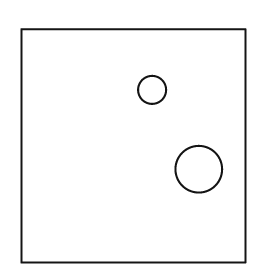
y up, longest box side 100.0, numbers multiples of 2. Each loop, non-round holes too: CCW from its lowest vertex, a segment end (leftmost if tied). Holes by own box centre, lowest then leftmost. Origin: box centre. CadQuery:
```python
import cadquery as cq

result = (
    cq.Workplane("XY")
    .moveTo(-48.0, -50.0)
    .lineTo(48.0, -50.0)
    .lineTo(48.0, 50.0)
    .lineTo(-48.0, 50.0)
    .close()
    .moveTo(28.0, -10.0)
    .circle(10.0)
    .moveTo(8.0, 24.0)
    .circle(6.0)
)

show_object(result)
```